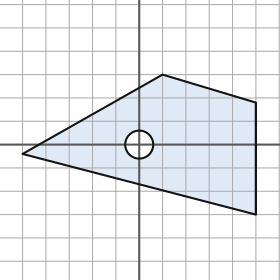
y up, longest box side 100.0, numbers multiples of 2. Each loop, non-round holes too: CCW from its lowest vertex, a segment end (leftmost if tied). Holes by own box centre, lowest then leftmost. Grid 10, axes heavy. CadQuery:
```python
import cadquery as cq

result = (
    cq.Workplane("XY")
    .moveTo(50.0, -30.0)
    .lineTo(50.0, 18.0)
    .lineTo(10.0, 30.0)
    .lineTo(-50.0, -4.0)
    .close()
    .moveTo(0.0, 0.0)
    .circle(6.0)
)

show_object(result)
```